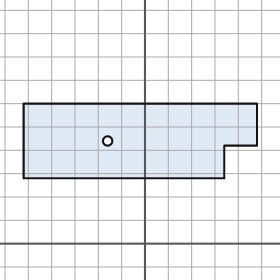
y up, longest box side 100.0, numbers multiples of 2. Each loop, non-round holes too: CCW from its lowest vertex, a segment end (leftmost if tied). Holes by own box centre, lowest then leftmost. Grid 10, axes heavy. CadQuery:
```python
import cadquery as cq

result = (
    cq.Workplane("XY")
    .moveTo(-52.0, 28.0)
    .lineTo(34.0, 28.0)
    .lineTo(34.0, 42.0)
    .lineTo(48.0, 42.0)
    .lineTo(48.0, 60.0)
    .lineTo(-52.0, 60.0)
    .close()
    .moveTo(-16.0, 44.0)
    .circle(2.0)
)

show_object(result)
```